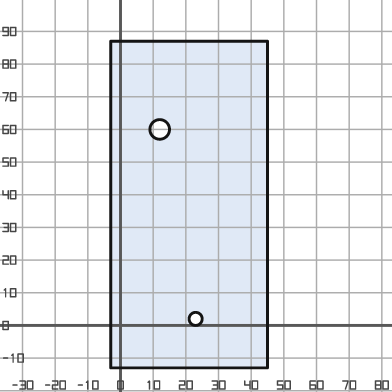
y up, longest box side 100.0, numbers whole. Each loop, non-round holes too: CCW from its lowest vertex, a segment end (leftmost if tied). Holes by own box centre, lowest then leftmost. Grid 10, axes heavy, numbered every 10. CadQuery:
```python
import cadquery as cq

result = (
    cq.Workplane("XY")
    .moveTo(-3.0, -13.0)
    .lineTo(45.0, -13.0)
    .lineTo(45.0, 87.0)
    .lineTo(-3.0, 87.0)
    .close()
    .moveTo(23.0, 2.0)
    .circle(2.0)
    .moveTo(12.0, 60.0)
    .circle(3.0)
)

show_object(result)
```